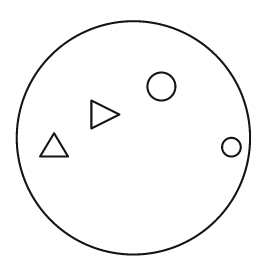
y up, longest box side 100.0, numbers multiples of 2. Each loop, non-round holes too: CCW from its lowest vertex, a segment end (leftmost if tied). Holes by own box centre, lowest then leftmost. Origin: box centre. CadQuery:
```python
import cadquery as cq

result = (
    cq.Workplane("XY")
    .moveTo(0.0, 0.0)
    .circle(50.0)
    .moveTo(42.0, -4.0)
    .circle(4.0)
    .moveTo(-40.0, -8.0)
    .lineTo(-28.0, -8.0)
    .lineTo(-34.0, 2.0)
    .close()
    .moveTo(-18.0, 4.0)
    .lineTo(-6.0, 10.0)
    .lineTo(-18.0, 16.0)
    .close()
    .moveTo(12.0, 22.0)
    .circle(6.0)
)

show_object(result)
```